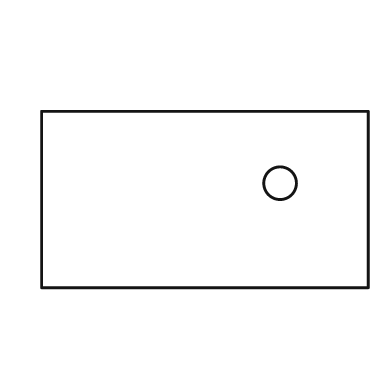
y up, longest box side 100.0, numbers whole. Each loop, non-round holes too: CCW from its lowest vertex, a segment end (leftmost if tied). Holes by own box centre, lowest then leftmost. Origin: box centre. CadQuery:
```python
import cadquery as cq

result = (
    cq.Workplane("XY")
    .moveTo(-50.0, -27.0)
    .lineTo(50.0, -27.0)
    .lineTo(50.0, 27.0)
    .lineTo(-50.0, 27.0)
    .close()
    .moveTo(23.0, 5.0)
    .circle(5.0)
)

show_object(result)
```